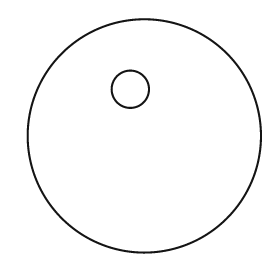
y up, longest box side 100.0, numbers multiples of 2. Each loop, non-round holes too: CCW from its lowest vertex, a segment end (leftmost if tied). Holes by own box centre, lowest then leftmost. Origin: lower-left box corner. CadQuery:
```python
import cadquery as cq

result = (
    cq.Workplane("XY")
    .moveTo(50.0, 50.0)
    .circle(50.0)
    .moveTo(44.0, 70.0)
    .circle(8.0)
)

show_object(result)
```